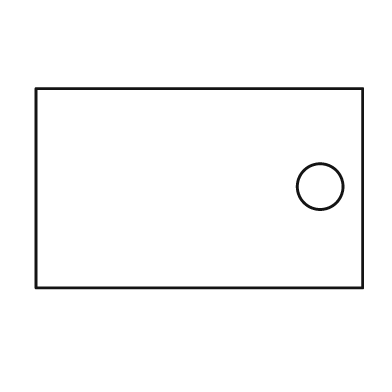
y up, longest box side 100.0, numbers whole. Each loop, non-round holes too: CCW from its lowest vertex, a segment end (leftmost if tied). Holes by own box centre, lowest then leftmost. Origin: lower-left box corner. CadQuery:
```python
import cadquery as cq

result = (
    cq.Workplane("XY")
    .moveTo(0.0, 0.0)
    .lineTo(100.0, 0.0)
    .lineTo(100.0, 61.0)
    .lineTo(0.0, 61.0)
    .close()
    .moveTo(87.0, 31.0)
    .circle(7.0)
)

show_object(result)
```